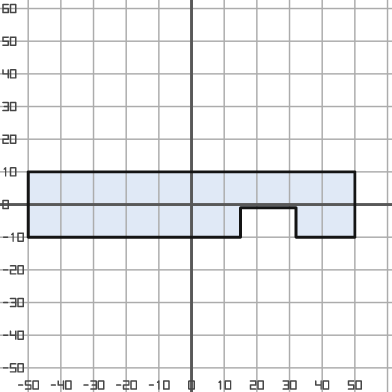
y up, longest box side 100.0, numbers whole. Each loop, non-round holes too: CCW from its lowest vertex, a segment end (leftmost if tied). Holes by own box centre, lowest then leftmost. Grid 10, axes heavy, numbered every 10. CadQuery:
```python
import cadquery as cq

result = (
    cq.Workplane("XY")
    .moveTo(-50.0, -10.0)
    .lineTo(15.0, -10.0)
    .lineTo(15.0, -1.0)
    .lineTo(32.0, -1.0)
    .lineTo(32.0, -10.0)
    .lineTo(50.0, -10.0)
    .lineTo(50.0, 10.0)
    .lineTo(-50.0, 10.0)
    .close()
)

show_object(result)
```